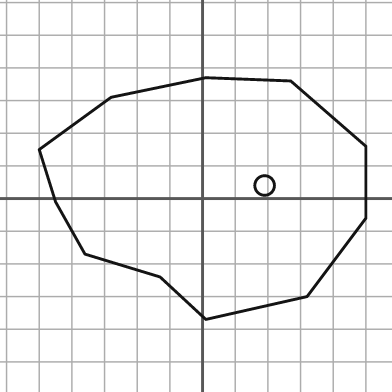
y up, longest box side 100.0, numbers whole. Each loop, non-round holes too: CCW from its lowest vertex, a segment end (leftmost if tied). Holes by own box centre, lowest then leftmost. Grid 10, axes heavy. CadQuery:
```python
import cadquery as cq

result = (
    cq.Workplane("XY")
    .moveTo(1.0, -37.0)
    .lineTo(32.0, -30.0)
    .lineTo(50.0, -6.0)
    .lineTo(50.0, 16.0)
    .lineTo(27.0, 36.0)
    .lineTo(1.0, 37.0)
    .lineTo(-28.0, 31.0)
    .lineTo(-50.0, 15.0)
    .lineTo(-45.0, -1.0)
    .lineTo(-36.0, -17.0)
    .lineTo(-13.0, -24.0)
    .close()
    .moveTo(19.0, 4.0)
    .circle(3.0)
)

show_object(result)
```